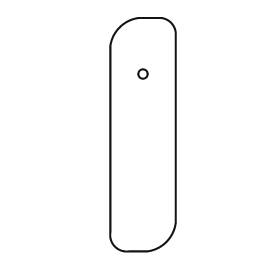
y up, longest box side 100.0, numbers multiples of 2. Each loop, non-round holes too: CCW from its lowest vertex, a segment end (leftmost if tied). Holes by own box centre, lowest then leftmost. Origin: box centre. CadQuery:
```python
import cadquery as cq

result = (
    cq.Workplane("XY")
    .moveTo(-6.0, -50.0)
    .lineTo(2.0, -50.0)
    .threePointArc((10.0, -46.0), (14.0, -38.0))
    .lineTo(14.0, 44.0)
    .threePointArc((12.0, 48.0), (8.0, 50.0))
    .lineTo(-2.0, 50.0)
    .threePointArc((-10.0, 46.0), (-14.0, 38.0))
    .lineTo(-14.0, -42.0)
    .threePointArc((-12.0, -48.0), (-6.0, -50.0))
    .close()
    .moveTo(0.0, 26.0)
    .circle(2.0)
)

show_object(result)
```